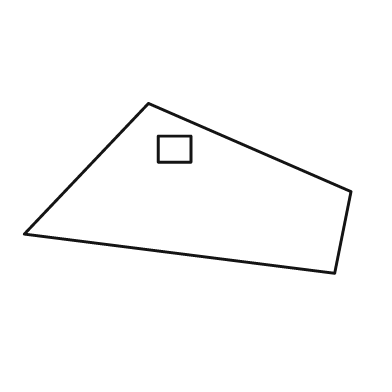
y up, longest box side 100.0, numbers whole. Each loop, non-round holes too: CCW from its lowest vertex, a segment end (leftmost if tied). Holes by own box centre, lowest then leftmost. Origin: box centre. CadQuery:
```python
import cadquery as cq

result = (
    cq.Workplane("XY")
    .moveTo(45.0, -26.0)
    .lineTo(50.0, -1.0)
    .lineTo(-12.0, 26.0)
    .lineTo(-50.0, -14.0)
    .close()
    .moveTo(-9.0, 8.0)
    .lineTo(1.0, 8.0)
    .lineTo(1.0, 16.0)
    .lineTo(-9.0, 16.0)
    .close()
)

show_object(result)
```